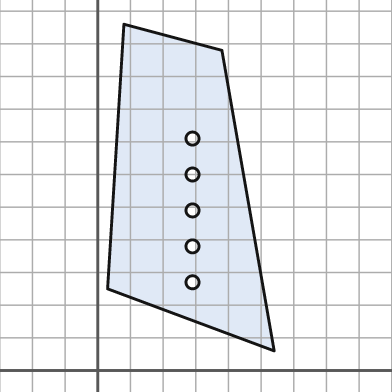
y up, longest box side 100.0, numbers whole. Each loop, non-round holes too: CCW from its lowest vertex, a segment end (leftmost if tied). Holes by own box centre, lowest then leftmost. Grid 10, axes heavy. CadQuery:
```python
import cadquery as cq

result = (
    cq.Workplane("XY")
    .moveTo(54.0, 6.0)
    .lineTo(38.0, 98.0)
    .lineTo(8.0, 106.0)
    .lineTo(3.0, 25.0)
    .close()
    .moveTo(29.0, 27.0)
    .circle(2.0)
    .moveTo(29.0, 38.0)
    .circle(2.0)
    .moveTo(29.0, 49.0)
    .circle(2.0)
    .moveTo(29.0, 60.0)
    .circle(2.0)
    .moveTo(29.0, 71.0)
    .circle(2.0)
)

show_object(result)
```